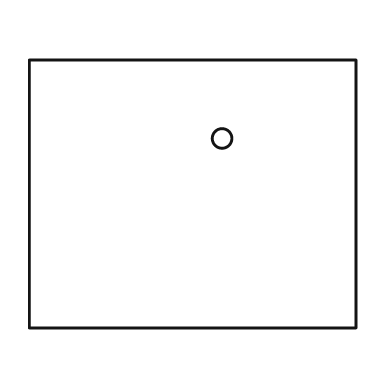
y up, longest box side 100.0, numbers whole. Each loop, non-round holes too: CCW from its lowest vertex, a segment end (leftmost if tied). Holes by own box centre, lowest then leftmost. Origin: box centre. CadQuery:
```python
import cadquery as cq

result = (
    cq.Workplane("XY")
    .moveTo(-50.0, -41.0)
    .lineTo(50.0, -41.0)
    .lineTo(50.0, 41.0)
    .lineTo(-50.0, 41.0)
    .close()
    .moveTo(9.0, 17.0)
    .circle(3.0)
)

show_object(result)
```